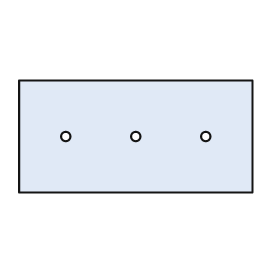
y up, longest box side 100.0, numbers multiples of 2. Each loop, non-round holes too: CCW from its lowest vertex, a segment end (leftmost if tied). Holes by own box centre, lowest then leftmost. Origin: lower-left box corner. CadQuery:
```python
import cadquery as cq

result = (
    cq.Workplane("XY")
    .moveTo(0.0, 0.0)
    .lineTo(100.0, 0.0)
    .lineTo(100.0, 48.0)
    .lineTo(0.0, 48.0)
    .close()
    .moveTo(20.0, 24.0)
    .circle(2.0)
    .moveTo(50.0, 24.0)
    .circle(2.0)
    .moveTo(80.0, 24.0)
    .circle(2.0)
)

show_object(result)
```